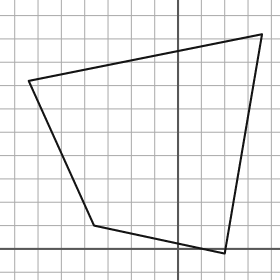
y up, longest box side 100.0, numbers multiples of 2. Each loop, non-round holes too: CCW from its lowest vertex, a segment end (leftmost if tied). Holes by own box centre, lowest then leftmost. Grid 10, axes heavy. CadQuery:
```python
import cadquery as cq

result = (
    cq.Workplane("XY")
    .moveTo(20.0, -2.0)
    .lineTo(36.0, 92.0)
    .lineTo(-64.0, 72.0)
    .lineTo(-36.0, 10.0)
    .close()
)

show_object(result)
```